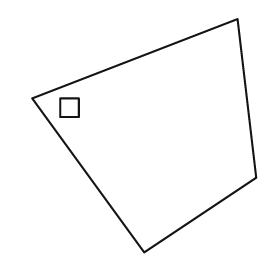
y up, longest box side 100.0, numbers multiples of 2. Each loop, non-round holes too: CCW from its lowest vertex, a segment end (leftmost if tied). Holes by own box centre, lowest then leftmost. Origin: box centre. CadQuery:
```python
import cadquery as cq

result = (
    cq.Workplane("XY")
    .moveTo(0.0, -50.0)
    .lineTo(48.0, -18.0)
    .lineTo(40.0, 50.0)
    .lineTo(-48.0, 16.0)
    .close()
    .moveTo(-36.0, 8.0)
    .lineTo(-28.0, 8.0)
    .lineTo(-28.0, 16.0)
    .lineTo(-36.0, 16.0)
    .close()
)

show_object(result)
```